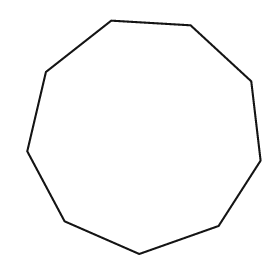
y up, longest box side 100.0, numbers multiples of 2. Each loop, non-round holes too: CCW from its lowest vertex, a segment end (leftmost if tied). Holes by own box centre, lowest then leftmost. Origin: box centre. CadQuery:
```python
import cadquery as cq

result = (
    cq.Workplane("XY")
    .moveTo(-2.0, -50.0)
    .lineTo(32.0, -38.0)
    .lineTo(50.0, -10.0)
    .lineTo(46.0, 24.0)
    .lineTo(20.0, 48.0)
    .lineTo(-14.0, 50.0)
    .lineTo(-42.0, 28.0)
    .lineTo(-50.0, -6.0)
    .lineTo(-34.0, -36.0)
    .close()
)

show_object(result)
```